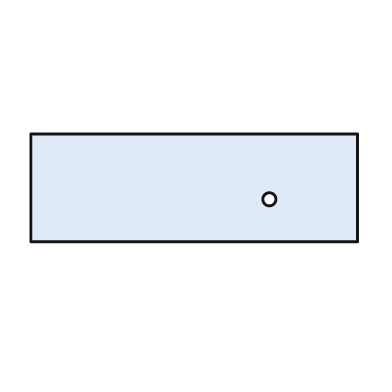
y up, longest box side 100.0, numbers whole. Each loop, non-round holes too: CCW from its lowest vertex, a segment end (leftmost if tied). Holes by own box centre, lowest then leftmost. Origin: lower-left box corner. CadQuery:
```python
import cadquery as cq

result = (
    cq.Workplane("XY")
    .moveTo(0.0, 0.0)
    .lineTo(100.0, 0.0)
    .lineTo(100.0, 33.0)
    .lineTo(0.0, 33.0)
    .close()
    .moveTo(73.0, 13.0)
    .circle(2.0)
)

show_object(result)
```